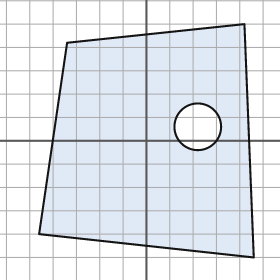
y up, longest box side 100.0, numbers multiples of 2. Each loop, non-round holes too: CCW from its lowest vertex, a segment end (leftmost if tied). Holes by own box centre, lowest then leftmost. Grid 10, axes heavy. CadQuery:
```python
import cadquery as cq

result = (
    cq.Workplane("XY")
    .moveTo(46.0, -50.0)
    .lineTo(42.0, 50.0)
    .lineTo(-34.0, 42.0)
    .lineTo(-46.0, -40.0)
    .close()
    .moveTo(22.0, 6.0)
    .circle(10.0)
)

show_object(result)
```